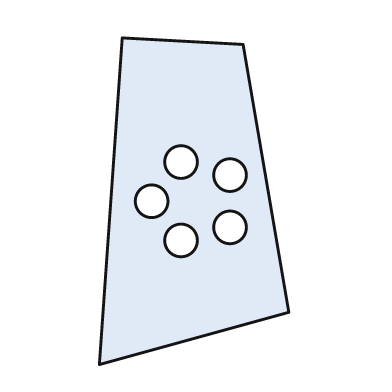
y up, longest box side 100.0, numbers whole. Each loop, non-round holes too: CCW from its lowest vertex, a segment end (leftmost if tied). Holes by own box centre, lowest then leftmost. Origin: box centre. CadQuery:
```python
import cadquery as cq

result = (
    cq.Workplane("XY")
    .moveTo(-29.0, -50.0)
    .lineTo(29.0, -34.0)
    .lineTo(15.0, 48.0)
    .lineTo(-22.0, 50.0)
    .close()
    .moveTo(-4.0, -12.0)
    .circle(5.0)
    .moveTo(11.0, -8.0)
    .circle(5.0)
    .moveTo(-13.0, 0.0)
    .circle(5.0)
    .moveTo(11.0, 8.0)
    .circle(5.0)
    .moveTo(-4.0, 12.0)
    .circle(5.0)
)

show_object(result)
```